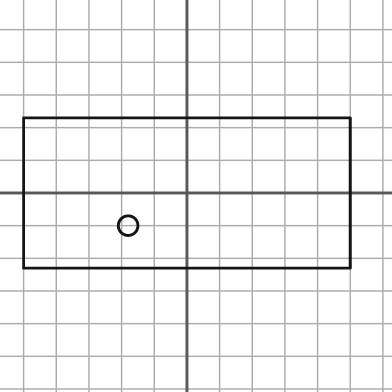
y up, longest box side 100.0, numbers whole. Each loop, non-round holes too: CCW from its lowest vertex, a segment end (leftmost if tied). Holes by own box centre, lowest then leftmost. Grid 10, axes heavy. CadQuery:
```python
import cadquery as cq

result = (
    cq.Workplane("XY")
    .moveTo(-50.0, -23.0)
    .lineTo(50.0, -23.0)
    .lineTo(50.0, 23.0)
    .lineTo(-50.0, 23.0)
    .close()
    .moveTo(-18.0, -10.0)
    .circle(3.0)
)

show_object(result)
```